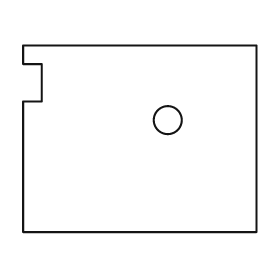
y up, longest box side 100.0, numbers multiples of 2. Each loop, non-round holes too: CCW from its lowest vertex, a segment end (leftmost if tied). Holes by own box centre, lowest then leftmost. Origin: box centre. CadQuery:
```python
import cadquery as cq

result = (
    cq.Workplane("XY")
    .moveTo(-50.0, -40.0)
    .lineTo(50.0, -40.0)
    .lineTo(50.0, 40.0)
    .lineTo(-50.0, 40.0)
    .lineTo(-50.0, 32.0)
    .lineTo(-42.0, 32.0)
    .lineTo(-42.0, 16.0)
    .lineTo(-50.0, 16.0)
    .close()
    .moveTo(12.0, 8.0)
    .circle(6.0)
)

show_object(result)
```